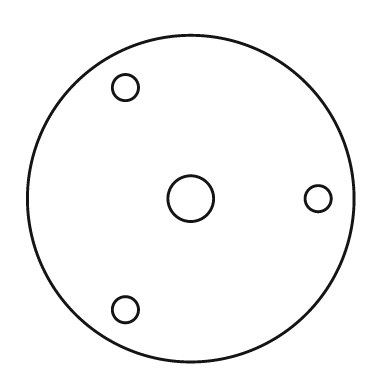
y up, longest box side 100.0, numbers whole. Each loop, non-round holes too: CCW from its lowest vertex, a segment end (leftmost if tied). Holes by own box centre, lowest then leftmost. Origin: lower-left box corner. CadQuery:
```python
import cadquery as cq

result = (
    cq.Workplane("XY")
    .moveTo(50.0, 50.0)
    .circle(50.0)
    .moveTo(30.0, 16.0)
    .circle(4.0)
    .moveTo(50.0, 50.0)
    .circle(7.0)
    .moveTo(89.0, 50.0)
    .circle(4.0)
    .moveTo(30.0, 84.0)
    .circle(4.0)
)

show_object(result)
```